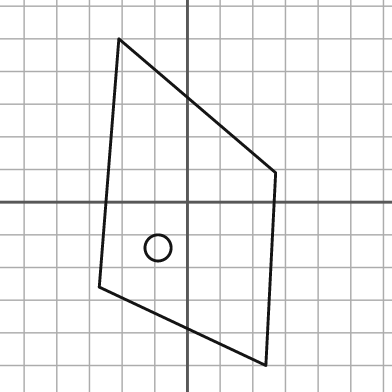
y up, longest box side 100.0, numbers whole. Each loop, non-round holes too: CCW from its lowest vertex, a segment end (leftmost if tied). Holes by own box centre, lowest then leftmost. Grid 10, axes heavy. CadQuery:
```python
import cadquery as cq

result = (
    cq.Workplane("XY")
    .moveTo(24.0, -50.0)
    .lineTo(27.0, 9.0)
    .lineTo(-21.0, 50.0)
    .lineTo(-27.0, -26.0)
    .close()
    .moveTo(-9.0, -14.0)
    .circle(4.0)
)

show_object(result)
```